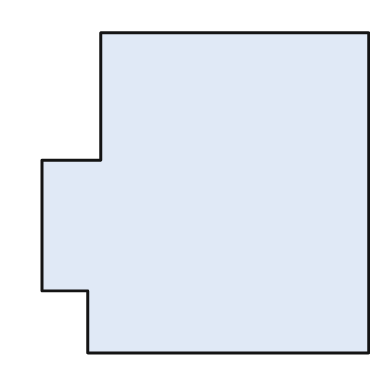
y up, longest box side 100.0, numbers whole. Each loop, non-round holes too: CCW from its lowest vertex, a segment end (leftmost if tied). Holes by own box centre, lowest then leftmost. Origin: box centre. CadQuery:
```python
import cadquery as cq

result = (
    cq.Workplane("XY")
    .moveTo(-36.0, -49.0)
    .lineTo(50.0, -49.0)
    .lineTo(50.0, 49.0)
    .lineTo(-32.0, 49.0)
    .lineTo(-32.0, 10.0)
    .lineTo(-50.0, 10.0)
    .lineTo(-50.0, -30.0)
    .lineTo(-36.0, -30.0)
    .close()
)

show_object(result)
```